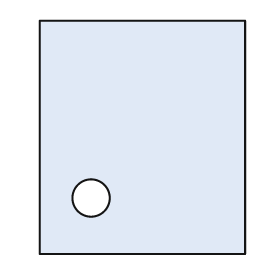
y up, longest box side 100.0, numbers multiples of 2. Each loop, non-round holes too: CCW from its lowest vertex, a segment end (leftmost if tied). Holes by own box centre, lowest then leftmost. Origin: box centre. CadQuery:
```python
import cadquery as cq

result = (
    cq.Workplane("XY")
    .moveTo(-44.0, -50.0)
    .lineTo(44.0, -50.0)
    .lineTo(44.0, 50.0)
    .lineTo(-44.0, 50.0)
    .close()
    .moveTo(-22.0, -26.0)
    .circle(8.0)
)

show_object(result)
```